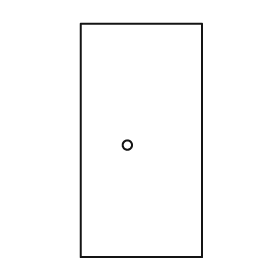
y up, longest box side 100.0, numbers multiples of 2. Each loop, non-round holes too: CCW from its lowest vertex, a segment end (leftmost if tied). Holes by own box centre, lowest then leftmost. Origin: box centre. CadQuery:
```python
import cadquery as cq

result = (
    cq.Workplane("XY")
    .moveTo(-26.0, -50.0)
    .lineTo(26.0, -50.0)
    .lineTo(26.0, 50.0)
    .lineTo(-26.0, 50.0)
    .close()
    .moveTo(-6.0, -2.0)
    .circle(2.0)
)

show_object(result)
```